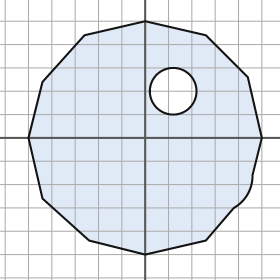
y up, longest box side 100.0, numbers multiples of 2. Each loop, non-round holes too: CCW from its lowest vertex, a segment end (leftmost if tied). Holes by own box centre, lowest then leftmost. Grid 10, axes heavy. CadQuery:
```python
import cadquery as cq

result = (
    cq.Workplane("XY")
    .moveTo(0.0, -50.0)
    .lineTo(26.0, -44.0)
    .lineTo(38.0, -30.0)
    .threePointArc((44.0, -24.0), (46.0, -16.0))
    .lineTo(50.0, 0.0)
    .lineTo(44.0, 26.0)
    .lineTo(26.0, 44.0)
    .lineTo(0.0, 50.0)
    .lineTo(-26.0, 44.0)
    .lineTo(-44.0, 24.0)
    .lineTo(-50.0, 0.0)
    .lineTo(-44.0, -26.0)
    .lineTo(-24.0, -44.0)
    .close()
    .moveTo(12.0, 20.0)
    .circle(10.0)
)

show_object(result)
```